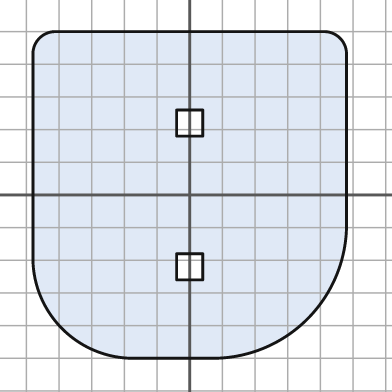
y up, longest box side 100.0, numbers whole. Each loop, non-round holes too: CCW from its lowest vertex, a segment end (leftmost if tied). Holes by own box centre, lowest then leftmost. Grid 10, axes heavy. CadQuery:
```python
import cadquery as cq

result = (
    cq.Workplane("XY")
    .moveTo(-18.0, -50.0)
    .lineTo(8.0, -50.0)
    .threePointArc((36.0, -38.0), (48.0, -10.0))
    .lineTo(48.0, 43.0)
    .threePointArc((46.0, 48.0), (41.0, 50.0))
    .lineTo(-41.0, 50.0)
    .threePointArc((-46.0, 48.0), (-48.0, 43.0))
    .lineTo(-48.0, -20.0)
    .threePointArc((-39.0, -41.0), (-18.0, -50.0))
    .close()
    .moveTo(-4.0, -26.0)
    .lineTo(4.0, -26.0)
    .lineTo(4.0, -18.0)
    .lineTo(-4.0, -18.0)
    .close()
    .moveTo(-4.0, 18.0)
    .lineTo(4.0, 18.0)
    .lineTo(4.0, 26.0)
    .lineTo(-4.0, 26.0)
    .close()
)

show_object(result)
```